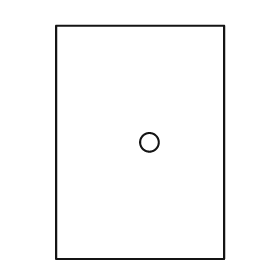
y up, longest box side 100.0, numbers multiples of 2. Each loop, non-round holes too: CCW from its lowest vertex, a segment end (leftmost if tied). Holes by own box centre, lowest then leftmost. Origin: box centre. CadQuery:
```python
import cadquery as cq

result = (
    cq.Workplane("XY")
    .moveTo(-36.0, -50.0)
    .lineTo(36.0, -50.0)
    .lineTo(36.0, 50.0)
    .lineTo(-36.0, 50.0)
    .close()
    .moveTo(4.0, 0.0)
    .circle(4.0)
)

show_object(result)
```